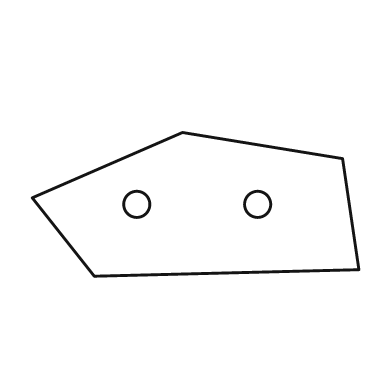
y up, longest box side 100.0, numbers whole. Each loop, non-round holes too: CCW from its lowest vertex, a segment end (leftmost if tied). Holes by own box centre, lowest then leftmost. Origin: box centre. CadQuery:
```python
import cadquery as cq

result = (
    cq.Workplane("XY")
    .moveTo(-31.0, -22.0)
    .lineTo(50.0, -20.0)
    .lineTo(45.0, 14.0)
    .lineTo(-4.0, 22.0)
    .lineTo(-50.0, 2.0)
    .close()
    .moveTo(-18.0, 0.0)
    .circle(4.0)
    .moveTo(19.0, 0.0)
    .circle(4.0)
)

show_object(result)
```